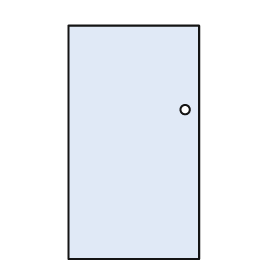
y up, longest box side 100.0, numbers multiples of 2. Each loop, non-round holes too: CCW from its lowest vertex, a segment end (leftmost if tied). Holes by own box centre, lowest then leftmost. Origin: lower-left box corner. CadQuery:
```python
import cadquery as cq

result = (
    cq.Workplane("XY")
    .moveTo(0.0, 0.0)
    .lineTo(56.0, 0.0)
    .lineTo(56.0, 100.0)
    .lineTo(0.0, 100.0)
    .close()
    .moveTo(50.0, 64.0)
    .circle(2.0)
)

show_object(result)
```